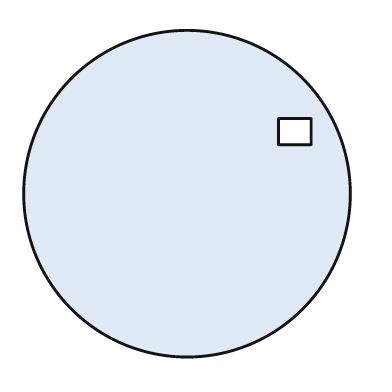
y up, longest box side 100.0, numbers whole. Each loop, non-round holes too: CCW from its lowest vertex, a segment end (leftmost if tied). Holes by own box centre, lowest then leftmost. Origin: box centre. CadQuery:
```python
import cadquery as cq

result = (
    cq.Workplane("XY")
    .moveTo(0.0, 0.0)
    .circle(50.0)
    .moveTo(28.0, 15.0)
    .lineTo(38.0, 15.0)
    .lineTo(38.0, 23.0)
    .lineTo(28.0, 23.0)
    .close()
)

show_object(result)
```